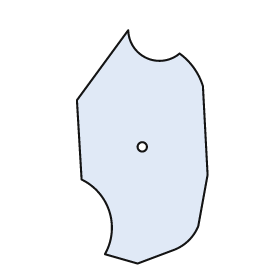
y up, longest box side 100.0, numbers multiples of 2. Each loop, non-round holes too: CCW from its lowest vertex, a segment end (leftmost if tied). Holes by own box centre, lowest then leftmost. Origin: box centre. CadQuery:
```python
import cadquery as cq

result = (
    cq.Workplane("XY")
    .moveTo(-2.0, -50.0)
    .lineTo(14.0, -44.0)
    .threePointArc((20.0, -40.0), (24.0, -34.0))
    .lineTo(28.0, -12.0)
    .lineTo(26.0, 26.0)
    .threePointArc((22.0, 34.0), (16.0, 40.0))
    .threePointArc((2.0, 38.0), (-6.0, 50.0))
    .lineTo(-28.0, 20.0)
    .lineTo(-26.0, -14.0)
    .threePointArc((-14.0, -28.0), (-16.0, -46.0))
    .close()
    .moveTo(0.0, 0.0)
    .circle(2.0)
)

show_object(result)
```